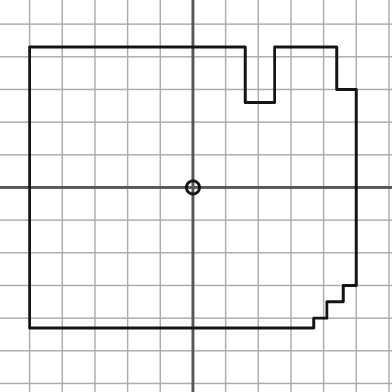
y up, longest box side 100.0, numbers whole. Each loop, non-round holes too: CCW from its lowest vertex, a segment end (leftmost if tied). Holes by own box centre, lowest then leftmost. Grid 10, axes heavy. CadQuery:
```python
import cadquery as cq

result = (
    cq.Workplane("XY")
    .moveTo(-50.0, -43.0)
    .lineTo(37.0, -43.0)
    .lineTo(37.0, -40.0)
    .lineTo(41.0, -40.0)
    .lineTo(41.0, -35.0)
    .lineTo(46.0, -35.0)
    .lineTo(46.0, -30.0)
    .lineTo(50.0, -30.0)
    .lineTo(50.0, 30.0)
    .lineTo(44.0, 30.0)
    .lineTo(44.0, 43.0)
    .lineTo(25.0, 43.0)
    .lineTo(25.0, 26.0)
    .lineTo(16.0, 26.0)
    .lineTo(16.0, 43.0)
    .lineTo(-50.0, 43.0)
    .close()
    .moveTo(0.0, 0.0)
    .circle(2.0)
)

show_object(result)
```